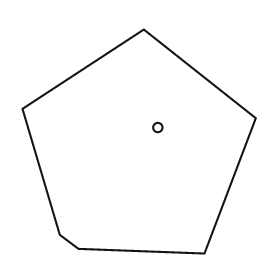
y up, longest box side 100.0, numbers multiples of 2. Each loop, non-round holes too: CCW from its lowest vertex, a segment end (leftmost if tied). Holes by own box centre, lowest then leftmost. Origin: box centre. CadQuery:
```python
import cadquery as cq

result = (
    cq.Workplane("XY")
    .moveTo(28.0, -48.0)
    .lineTo(50.0, 10.0)
    .lineTo(2.0, 48.0)
    .lineTo(-50.0, 14.0)
    .lineTo(-34.0, -40.0)
    .lineTo(-26.0, -46.0)
    .close()
    .moveTo(8.0, 6.0)
    .circle(2.0)
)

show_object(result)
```